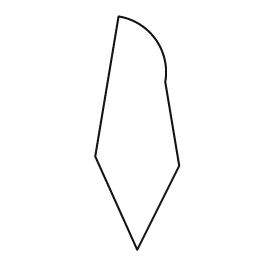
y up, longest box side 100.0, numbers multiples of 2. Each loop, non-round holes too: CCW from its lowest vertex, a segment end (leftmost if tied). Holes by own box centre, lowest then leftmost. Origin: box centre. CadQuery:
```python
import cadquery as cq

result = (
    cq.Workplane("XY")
    .moveTo(0.0, -50.0)
    .lineTo(18.0, -14.0)
    .lineTo(12.0, 22.0)
    .threePointArc((8.0, 40.0), (-8.0, 50.0))
    .lineTo(-18.0, -10.0)
    .close()
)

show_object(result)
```